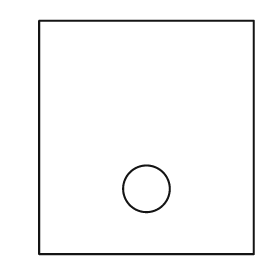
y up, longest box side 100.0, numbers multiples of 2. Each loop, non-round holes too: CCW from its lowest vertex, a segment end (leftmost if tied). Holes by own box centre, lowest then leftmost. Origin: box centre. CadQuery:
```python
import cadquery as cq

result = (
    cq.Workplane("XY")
    .moveTo(-46.0, -50.0)
    .lineTo(46.0, -50.0)
    .lineTo(46.0, 50.0)
    .lineTo(-46.0, 50.0)
    .close()
    .moveTo(0.0, -22.0)
    .circle(10.0)
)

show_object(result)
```